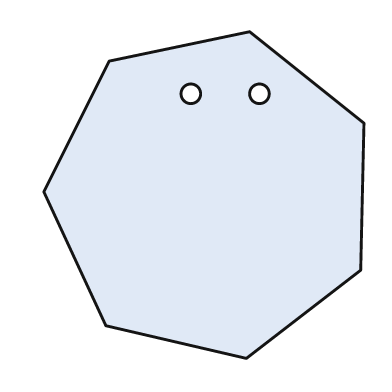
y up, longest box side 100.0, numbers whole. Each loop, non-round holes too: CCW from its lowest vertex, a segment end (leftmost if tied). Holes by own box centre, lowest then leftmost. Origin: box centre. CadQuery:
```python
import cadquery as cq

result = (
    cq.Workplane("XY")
    .moveTo(13.0, -50.0)
    .lineTo(48.0, -23.0)
    .lineTo(49.0, 22.0)
    .lineTo(14.0, 50.0)
    .lineTo(-29.0, 41.0)
    .lineTo(-49.0, 1.0)
    .lineTo(-30.0, -40.0)
    .close()
    .moveTo(-4.0, 31.0)
    .circle(3.0)
    .moveTo(17.0, 31.0)
    .circle(3.0)
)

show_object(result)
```